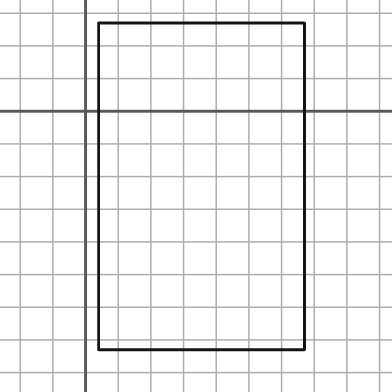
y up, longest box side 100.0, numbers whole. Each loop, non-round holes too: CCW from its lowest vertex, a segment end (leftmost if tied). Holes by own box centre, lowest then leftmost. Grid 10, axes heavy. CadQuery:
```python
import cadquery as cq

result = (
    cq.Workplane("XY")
    .moveTo(4.0, -73.0)
    .lineTo(67.0, -73.0)
    .lineTo(67.0, 27.0)
    .lineTo(4.0, 27.0)
    .close()
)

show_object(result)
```